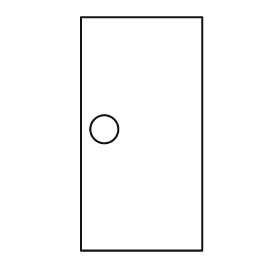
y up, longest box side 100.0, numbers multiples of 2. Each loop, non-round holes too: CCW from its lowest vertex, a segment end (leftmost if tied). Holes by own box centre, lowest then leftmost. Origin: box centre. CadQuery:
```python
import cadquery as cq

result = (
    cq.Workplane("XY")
    .moveTo(-26.0, -50.0)
    .lineTo(26.0, -50.0)
    .lineTo(26.0, 50.0)
    .lineTo(-26.0, 50.0)
    .close()
    .moveTo(-16.0, 2.0)
    .circle(6.0)
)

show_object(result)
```